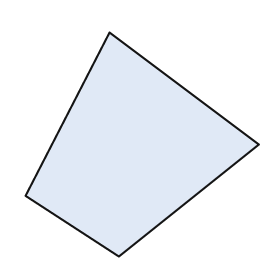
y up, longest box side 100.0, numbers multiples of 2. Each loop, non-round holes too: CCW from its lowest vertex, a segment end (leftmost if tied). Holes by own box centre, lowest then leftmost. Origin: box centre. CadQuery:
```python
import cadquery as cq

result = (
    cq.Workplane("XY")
    .moveTo(-10.0, -48.0)
    .lineTo(50.0, 0.0)
    .lineTo(-14.0, 48.0)
    .lineTo(-50.0, -22.0)
    .close()
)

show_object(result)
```